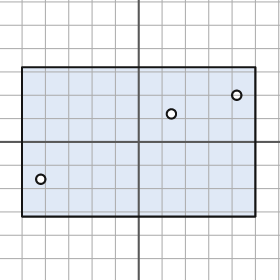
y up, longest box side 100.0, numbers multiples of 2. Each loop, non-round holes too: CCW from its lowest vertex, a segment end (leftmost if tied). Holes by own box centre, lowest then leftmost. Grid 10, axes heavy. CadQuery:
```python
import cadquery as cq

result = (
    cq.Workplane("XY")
    .moveTo(-50.0, -32.0)
    .lineTo(50.0, -32.0)
    .lineTo(50.0, 32.0)
    .lineTo(-50.0, 32.0)
    .close()
    .moveTo(-42.0, -16.0)
    .circle(2.0)
    .moveTo(14.0, 12.0)
    .circle(2.0)
    .moveTo(42.0, 20.0)
    .circle(2.0)
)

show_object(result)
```